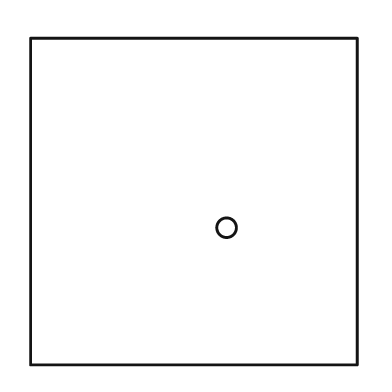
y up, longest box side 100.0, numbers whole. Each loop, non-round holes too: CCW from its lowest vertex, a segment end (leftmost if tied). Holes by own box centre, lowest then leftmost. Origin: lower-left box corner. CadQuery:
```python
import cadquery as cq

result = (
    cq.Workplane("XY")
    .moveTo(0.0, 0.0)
    .lineTo(100.0, 0.0)
    .lineTo(100.0, 100.0)
    .lineTo(0.0, 100.0)
    .close()
    .moveTo(60.0, 42.0)
    .circle(3.0)
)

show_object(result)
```